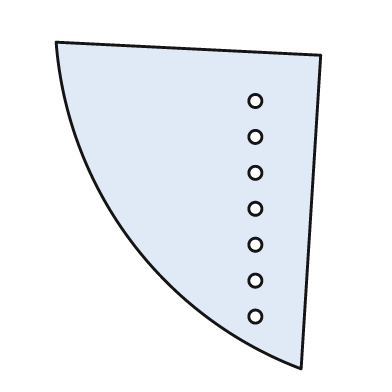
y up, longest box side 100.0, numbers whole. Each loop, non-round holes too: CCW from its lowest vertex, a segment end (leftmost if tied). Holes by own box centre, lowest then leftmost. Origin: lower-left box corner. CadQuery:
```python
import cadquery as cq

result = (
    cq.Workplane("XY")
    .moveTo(75.0, 0.0)
    .lineTo(81.0, 96.0)
    .lineTo(0.0, 100.0)
    .threePointArc((23.0, 39.0), (75.0, 0.0))
    .close()
    .moveTo(61.0, 16.0)
    .circle(2.0)
    .moveTo(61.0, 27.0)
    .circle(2.0)
    .moveTo(61.0, 38.0)
    .circle(2.0)
    .moveTo(61.0, 49.0)
    .circle(2.0)
    .moveTo(61.0, 60.0)
    .circle(2.0)
    .moveTo(61.0, 71.0)
    .circle(2.0)
    .moveTo(61.0, 82.0)
    .circle(2.0)
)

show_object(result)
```